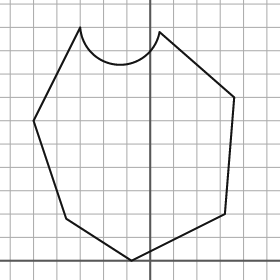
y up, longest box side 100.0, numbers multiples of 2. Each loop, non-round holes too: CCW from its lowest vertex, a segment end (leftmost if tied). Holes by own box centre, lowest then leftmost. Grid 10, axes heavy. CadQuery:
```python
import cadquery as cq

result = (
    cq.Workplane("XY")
    .moveTo(-8.0, 0.0)
    .lineTo(32.0, 20.0)
    .lineTo(36.0, 70.0)
    .lineTo(4.0, 98.0)
    .threePointArc((-14.0, 84.0), (-30.0, 100.0))
    .lineTo(-50.0, 60.0)
    .lineTo(-36.0, 18.0)
    .close()
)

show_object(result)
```